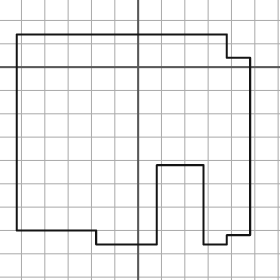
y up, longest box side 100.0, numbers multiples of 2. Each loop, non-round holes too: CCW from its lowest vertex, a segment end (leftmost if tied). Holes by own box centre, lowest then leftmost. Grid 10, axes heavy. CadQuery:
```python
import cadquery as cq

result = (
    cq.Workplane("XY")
    .moveTo(-18.0, -76.0)
    .lineTo(8.0, -76.0)
    .lineTo(8.0, -42.0)
    .lineTo(28.0, -42.0)
    .lineTo(28.0, -76.0)
    .lineTo(38.0, -76.0)
    .lineTo(38.0, -72.0)
    .lineTo(48.0, -72.0)
    .lineTo(48.0, 4.0)
    .lineTo(38.0, 4.0)
    .lineTo(38.0, 14.0)
    .lineTo(-52.0, 14.0)
    .lineTo(-52.0, -70.0)
    .lineTo(-18.0, -70.0)
    .close()
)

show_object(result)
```